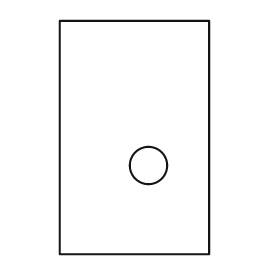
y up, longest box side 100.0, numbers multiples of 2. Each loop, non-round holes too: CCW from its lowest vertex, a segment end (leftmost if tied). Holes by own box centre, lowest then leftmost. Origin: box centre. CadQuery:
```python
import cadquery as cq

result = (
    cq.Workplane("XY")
    .moveTo(-32.0, -50.0)
    .lineTo(32.0, -50.0)
    .lineTo(32.0, 50.0)
    .lineTo(-32.0, 50.0)
    .close()
    .moveTo(6.0, -12.0)
    .circle(8.0)
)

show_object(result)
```